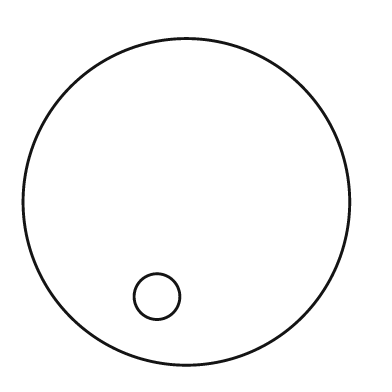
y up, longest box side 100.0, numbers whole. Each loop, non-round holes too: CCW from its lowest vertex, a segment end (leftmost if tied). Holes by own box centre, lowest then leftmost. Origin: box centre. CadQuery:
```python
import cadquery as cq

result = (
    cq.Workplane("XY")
    .moveTo(0.0, 0.0)
    .circle(50.0)
    .moveTo(-9.0, -29.0)
    .circle(7.0)
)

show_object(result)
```